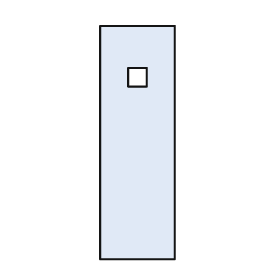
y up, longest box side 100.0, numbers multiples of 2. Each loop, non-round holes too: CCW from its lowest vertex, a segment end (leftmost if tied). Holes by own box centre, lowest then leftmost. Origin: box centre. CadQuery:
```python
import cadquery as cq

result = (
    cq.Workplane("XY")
    .moveTo(-16.0, -50.0)
    .lineTo(16.0, -50.0)
    .lineTo(16.0, 50.0)
    .lineTo(-16.0, 50.0)
    .close()
    .moveTo(-4.0, 24.0)
    .lineTo(4.0, 24.0)
    .lineTo(4.0, 32.0)
    .lineTo(-4.0, 32.0)
    .close()
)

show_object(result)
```